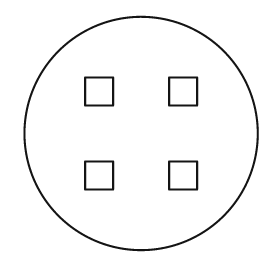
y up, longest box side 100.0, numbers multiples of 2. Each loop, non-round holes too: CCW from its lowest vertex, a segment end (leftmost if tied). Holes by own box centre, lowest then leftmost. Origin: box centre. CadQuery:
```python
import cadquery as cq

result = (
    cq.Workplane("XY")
    .moveTo(0.0, 0.0)
    .circle(50.0)
    .moveTo(-24.0, -24.0)
    .lineTo(-12.0, -24.0)
    .lineTo(-12.0, -12.0)
    .lineTo(-24.0, -12.0)
    .close()
    .moveTo(12.0, -24.0)
    .lineTo(24.0, -24.0)
    .lineTo(24.0, -12.0)
    .lineTo(12.0, -12.0)
    .close()
    .moveTo(-24.0, 12.0)
    .lineTo(-12.0, 12.0)
    .lineTo(-12.0, 24.0)
    .lineTo(-24.0, 24.0)
    .close()
    .moveTo(12.0, 12.0)
    .lineTo(24.0, 12.0)
    .lineTo(24.0, 24.0)
    .lineTo(12.0, 24.0)
    .close()
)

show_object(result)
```